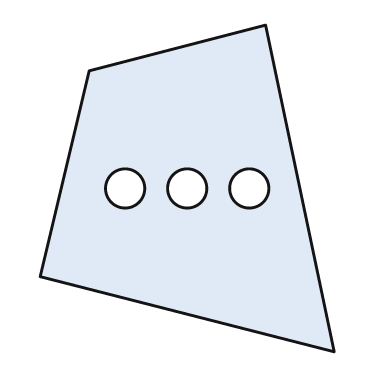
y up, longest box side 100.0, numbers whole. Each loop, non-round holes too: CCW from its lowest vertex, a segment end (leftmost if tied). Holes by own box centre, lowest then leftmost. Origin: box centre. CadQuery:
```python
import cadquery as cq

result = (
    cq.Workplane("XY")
    .moveTo(45.0, -50.0)
    .lineTo(24.0, 50.0)
    .lineTo(-30.0, 36.0)
    .lineTo(-45.0, -27.0)
    .close()
    .moveTo(-19.0, 0.0)
    .circle(6.0)
    .moveTo(0.0, 0.0)
    .circle(6.0)
    .moveTo(19.0, 0.0)
    .circle(6.0)
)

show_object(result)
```